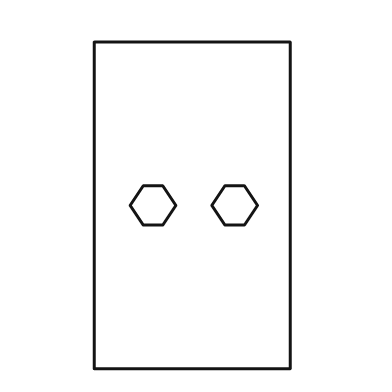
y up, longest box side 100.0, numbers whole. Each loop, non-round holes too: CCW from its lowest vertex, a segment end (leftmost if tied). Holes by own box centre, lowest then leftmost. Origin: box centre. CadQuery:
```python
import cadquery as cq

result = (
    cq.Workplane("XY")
    .moveTo(-30.0, -50.0)
    .lineTo(30.0, -50.0)
    .lineTo(30.0, 50.0)
    .lineTo(-30.0, 50.0)
    .close()
    .moveTo(-15.0, -6.0)
    .lineTo(-9.0, -6.0)
    .lineTo(-5.0, 0.0)
    .lineTo(-9.0, 6.0)
    .lineTo(-15.0, 6.0)
    .lineTo(-19.0, 0.0)
    .close()
    .moveTo(10.0, -6.0)
    .lineTo(16.0, -6.0)
    .lineTo(20.0, 0.0)
    .lineTo(16.0, 6.0)
    .lineTo(10.0, 6.0)
    .lineTo(6.0, 0.0)
    .close()
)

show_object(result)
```